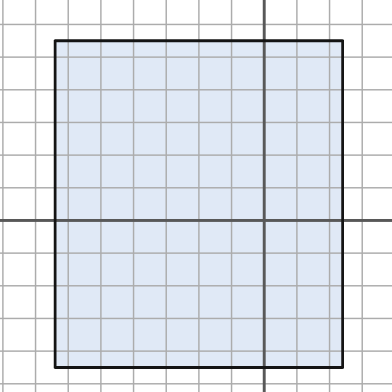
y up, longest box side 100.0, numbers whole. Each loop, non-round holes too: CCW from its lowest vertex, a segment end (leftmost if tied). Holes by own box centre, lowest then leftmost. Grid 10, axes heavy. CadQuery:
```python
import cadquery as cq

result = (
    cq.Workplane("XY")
    .moveTo(-64.0, -45.0)
    .lineTo(24.0, -45.0)
    .lineTo(24.0, 55.0)
    .lineTo(-64.0, 55.0)
    .close()
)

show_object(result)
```